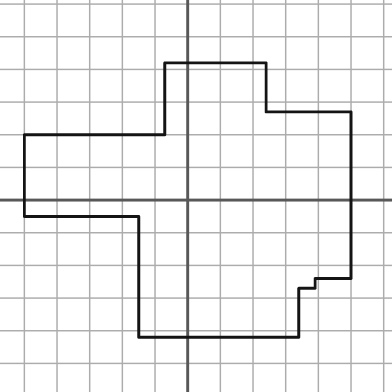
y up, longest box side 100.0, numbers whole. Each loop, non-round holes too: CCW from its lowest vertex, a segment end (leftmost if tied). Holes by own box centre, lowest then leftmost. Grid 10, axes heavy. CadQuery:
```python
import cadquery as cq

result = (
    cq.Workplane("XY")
    .moveTo(-15.0, -42.0)
    .lineTo(34.0, -42.0)
    .lineTo(34.0, -27.0)
    .lineTo(39.0, -27.0)
    .lineTo(39.0, -24.0)
    .lineTo(50.0, -24.0)
    .lineTo(50.0, 27.0)
    .lineTo(24.0, 27.0)
    .lineTo(24.0, 42.0)
    .lineTo(-7.0, 42.0)
    .lineTo(-7.0, 20.0)
    .lineTo(-50.0, 20.0)
    .lineTo(-50.0, -5.0)
    .lineTo(-15.0, -5.0)
    .close()
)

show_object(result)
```